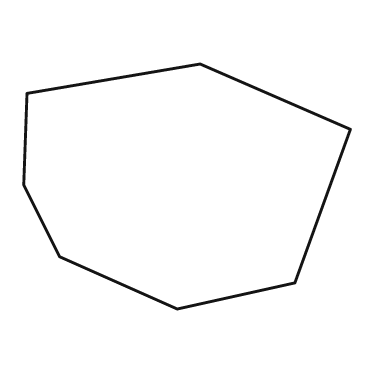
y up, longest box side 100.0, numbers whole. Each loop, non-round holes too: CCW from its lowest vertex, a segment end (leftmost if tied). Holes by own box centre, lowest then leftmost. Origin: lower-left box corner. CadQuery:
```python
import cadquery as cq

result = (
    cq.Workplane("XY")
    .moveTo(47.0, 0.0)
    .lineTo(83.0, 8.0)
    .lineTo(100.0, 55.0)
    .lineTo(54.0, 75.0)
    .lineTo(1.0, 66.0)
    .lineTo(0.0, 38.0)
    .lineTo(11.0, 16.0)
    .close()
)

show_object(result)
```